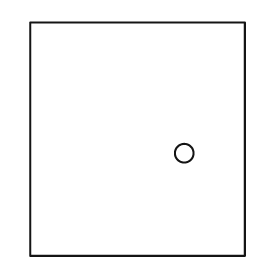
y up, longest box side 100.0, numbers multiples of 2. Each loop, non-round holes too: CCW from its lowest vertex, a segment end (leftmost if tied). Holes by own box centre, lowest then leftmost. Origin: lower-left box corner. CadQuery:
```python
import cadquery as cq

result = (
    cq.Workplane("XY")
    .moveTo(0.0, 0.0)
    .lineTo(92.0, 0.0)
    .lineTo(92.0, 100.0)
    .lineTo(0.0, 100.0)
    .close()
    .moveTo(66.0, 44.0)
    .circle(4.0)
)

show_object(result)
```